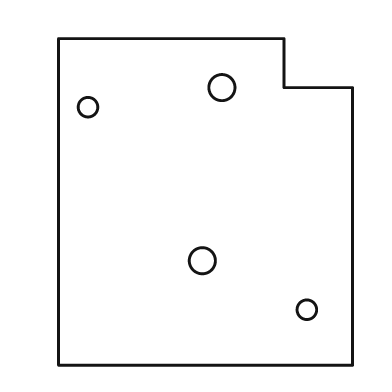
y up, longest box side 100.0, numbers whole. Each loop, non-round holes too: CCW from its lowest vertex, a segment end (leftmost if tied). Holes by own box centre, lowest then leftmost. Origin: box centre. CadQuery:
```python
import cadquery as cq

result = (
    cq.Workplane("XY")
    .moveTo(-45.0, -50.0)
    .lineTo(45.0, -50.0)
    .lineTo(45.0, 35.0)
    .lineTo(24.0, 35.0)
    .lineTo(24.0, 50.0)
    .lineTo(-45.0, 50.0)
    .close()
    .moveTo(31.0, -33.0)
    .circle(3.0)
    .moveTo(-1.0, -18.0)
    .circle(4.0)
    .moveTo(-36.0, 29.0)
    .circle(3.0)
    .moveTo(5.0, 35.0)
    .circle(4.0)
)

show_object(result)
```